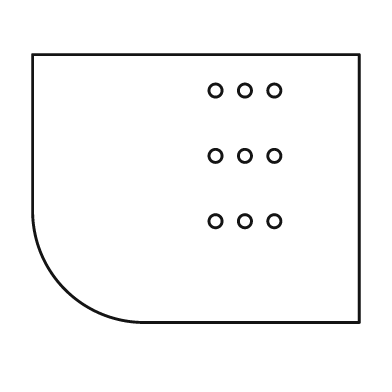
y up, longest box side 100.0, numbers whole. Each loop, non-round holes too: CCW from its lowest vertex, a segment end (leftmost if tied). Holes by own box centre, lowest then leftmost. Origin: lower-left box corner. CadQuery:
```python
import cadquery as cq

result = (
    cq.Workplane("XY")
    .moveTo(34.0, 0.0)
    .lineTo(100.0, 0.0)
    .lineTo(100.0, 82.0)
    .lineTo(0.0, 82.0)
    .lineTo(0.0, 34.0)
    .threePointArc((10.0, 10.0), (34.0, 0.0))
    .close()
    .moveTo(56.0, 31.0)
    .circle(2.0)
    .moveTo(65.0, 31.0)
    .circle(2.0)
    .moveTo(74.0, 31.0)
    .circle(2.0)
    .moveTo(56.0, 51.0)
    .circle(2.0)
    .moveTo(65.0, 51.0)
    .circle(2.0)
    .moveTo(74.0, 51.0)
    .circle(2.0)
    .moveTo(56.0, 71.0)
    .circle(2.0)
    .moveTo(65.0, 71.0)
    .circle(2.0)
    .moveTo(74.0, 71.0)
    .circle(2.0)
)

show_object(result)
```